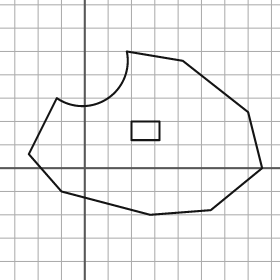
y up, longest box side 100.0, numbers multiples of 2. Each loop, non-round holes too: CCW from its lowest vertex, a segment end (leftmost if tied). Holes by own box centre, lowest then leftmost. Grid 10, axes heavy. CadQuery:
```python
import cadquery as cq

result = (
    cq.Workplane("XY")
    .moveTo(28.0, -20.0)
    .lineTo(54.0, -18.0)
    .lineTo(76.0, 0.0)
    .lineTo(70.0, 24.0)
    .lineTo(42.0, 46.0)
    .lineTo(18.0, 50.0)
    .threePointArc((10.0, 30.0), (-12.0, 30.0))
    .lineTo(-24.0, 6.0)
    .lineTo(-10.0, -10.0)
    .close()
    .moveTo(20.0, 12.0)
    .lineTo(32.0, 12.0)
    .lineTo(32.0, 20.0)
    .lineTo(20.0, 20.0)
    .close()
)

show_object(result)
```